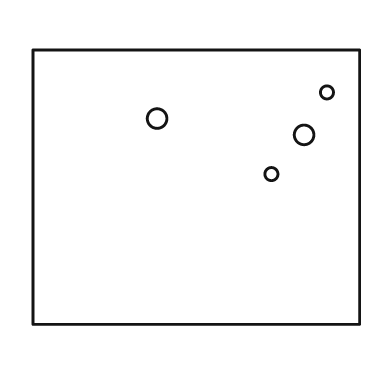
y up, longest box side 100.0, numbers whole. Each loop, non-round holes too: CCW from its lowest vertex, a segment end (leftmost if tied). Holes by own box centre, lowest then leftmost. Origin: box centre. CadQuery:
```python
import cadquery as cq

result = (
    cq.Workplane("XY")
    .moveTo(-50.0, -42.0)
    .lineTo(50.0, -42.0)
    .lineTo(50.0, 42.0)
    .lineTo(-50.0, 42.0)
    .close()
    .moveTo(23.0, 4.0)
    .circle(2.0)
    .moveTo(33.0, 16.0)
    .circle(3.0)
    .moveTo(-12.0, 21.0)
    .circle(3.0)
    .moveTo(40.0, 29.0)
    .circle(2.0)
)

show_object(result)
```